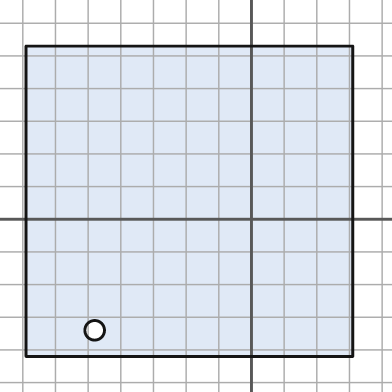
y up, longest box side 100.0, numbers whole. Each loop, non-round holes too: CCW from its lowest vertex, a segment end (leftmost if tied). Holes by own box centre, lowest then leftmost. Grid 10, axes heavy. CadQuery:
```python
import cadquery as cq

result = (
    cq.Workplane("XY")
    .moveTo(-69.0, -42.0)
    .lineTo(31.0, -42.0)
    .lineTo(31.0, 53.0)
    .lineTo(-69.0, 53.0)
    .close()
    .moveTo(-48.0, -34.0)
    .circle(3.0)
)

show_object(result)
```